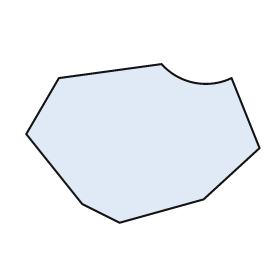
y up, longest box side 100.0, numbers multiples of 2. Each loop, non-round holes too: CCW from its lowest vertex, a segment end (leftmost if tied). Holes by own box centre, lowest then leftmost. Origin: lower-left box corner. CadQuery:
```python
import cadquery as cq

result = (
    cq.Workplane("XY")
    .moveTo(40.0, 0.0)
    .lineTo(76.0, 10.0)
    .lineTo(100.0, 32.0)
    .lineTo(88.0, 62.0)
    .threePointArc((72.0, 60.0), (58.0, 68.0))
    .lineTo(14.0, 62.0)
    .lineTo(0.0, 38.0)
    .lineTo(24.0, 8.0)
    .close()
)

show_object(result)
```